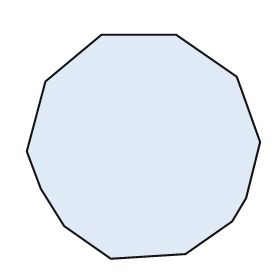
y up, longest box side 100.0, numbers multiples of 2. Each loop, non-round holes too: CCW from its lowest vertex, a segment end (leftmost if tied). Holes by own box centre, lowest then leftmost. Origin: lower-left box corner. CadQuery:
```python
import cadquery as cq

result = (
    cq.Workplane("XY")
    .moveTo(36.0, 0.0)
    .lineTo(68.0, 2.0)
    .lineTo(88.0, 16.0)
    .lineTo(94.0, 26.0)
    .lineTo(100.0, 50.0)
    .lineTo(90.0, 78.0)
    .lineTo(64.0, 96.0)
    .lineTo(32.0, 96.0)
    .lineTo(8.0, 76.0)
    .lineTo(0.0, 46.0)
    .lineTo(6.0, 30.0)
    .lineTo(16.0, 14.0)
    .close()
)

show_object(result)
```